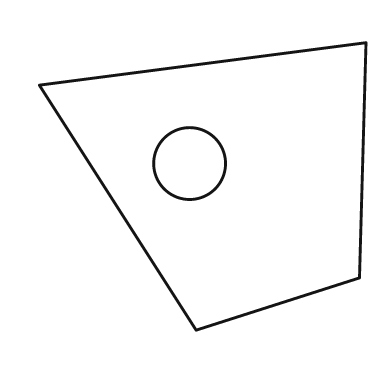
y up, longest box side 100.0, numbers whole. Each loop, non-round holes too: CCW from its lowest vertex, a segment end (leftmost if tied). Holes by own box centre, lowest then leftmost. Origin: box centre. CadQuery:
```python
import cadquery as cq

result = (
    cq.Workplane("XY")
    .moveTo(-2.0, -44.0)
    .lineTo(48.0, -28.0)
    .lineTo(50.0, 44.0)
    .lineTo(-50.0, 31.0)
    .close()
    .moveTo(-4.0, 7.0)
    .circle(11.0)
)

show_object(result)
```